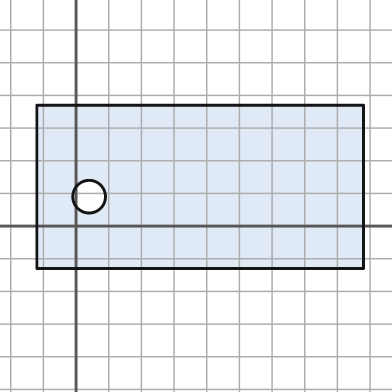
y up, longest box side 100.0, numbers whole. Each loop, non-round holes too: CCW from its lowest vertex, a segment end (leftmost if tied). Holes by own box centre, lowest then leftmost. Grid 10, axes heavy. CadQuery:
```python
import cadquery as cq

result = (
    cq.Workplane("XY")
    .moveTo(-12.0, -13.0)
    .lineTo(88.0, -13.0)
    .lineTo(88.0, 37.0)
    .lineTo(-12.0, 37.0)
    .close()
    .moveTo(4.0, 9.0)
    .circle(5.0)
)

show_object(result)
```